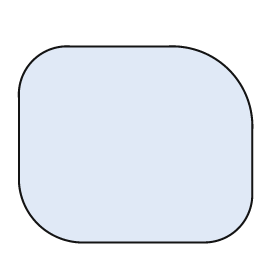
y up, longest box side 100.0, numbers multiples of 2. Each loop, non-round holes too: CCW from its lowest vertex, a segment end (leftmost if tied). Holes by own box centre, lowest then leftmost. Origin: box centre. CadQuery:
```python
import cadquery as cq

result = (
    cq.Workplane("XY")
    .moveTo(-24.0, -42.0)
    .lineTo(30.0, -42.0)
    .threePointArc((44.0, -36.0), (50.0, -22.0))
    .lineTo(50.0, 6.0)
    .threePointArc((40.0, 32.0), (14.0, 42.0))
    .lineTo(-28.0, 42.0)
    .threePointArc((-44.0, 36.0), (-50.0, 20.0))
    .lineTo(-50.0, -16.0)
    .threePointArc((-42.0, -34.0), (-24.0, -42.0))
    .close()
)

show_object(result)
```